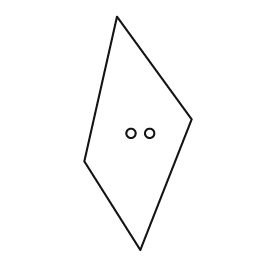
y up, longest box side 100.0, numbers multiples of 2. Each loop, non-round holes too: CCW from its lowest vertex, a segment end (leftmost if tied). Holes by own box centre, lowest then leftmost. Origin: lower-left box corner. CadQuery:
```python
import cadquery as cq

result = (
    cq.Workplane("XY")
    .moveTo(24.0, 0.0)
    .lineTo(46.0, 56.0)
    .lineTo(14.0, 100.0)
    .lineTo(0.0, 38.0)
    .close()
    .moveTo(20.0, 50.0)
    .circle(2.0)
    .moveTo(28.0, 50.0)
    .circle(2.0)
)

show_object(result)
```